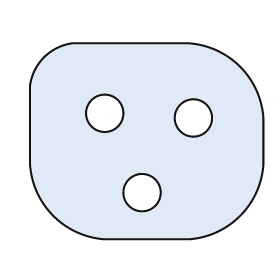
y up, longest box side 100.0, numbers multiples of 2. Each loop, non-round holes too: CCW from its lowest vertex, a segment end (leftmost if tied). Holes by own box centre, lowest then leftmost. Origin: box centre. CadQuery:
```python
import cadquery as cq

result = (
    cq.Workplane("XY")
    .moveTo(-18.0, -42.0)
    .lineTo(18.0, -42.0)
    .threePointArc((40.0, -32.0), (50.0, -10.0))
    .lineTo(50.0, 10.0)
    .threePointArc((40.0, 32.0), (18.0, 42.0))
    .lineTo(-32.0, 42.0)
    .threePointArc((-44.0, 36.0), (-50.0, 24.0))
    .lineTo(-50.0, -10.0)
    .threePointArc((-40.0, -32.0), (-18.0, -42.0))
    .close()
    .moveTo(-2.0, -22.0)
    .circle(8.0)
    .moveTo(20.0, 10.0)
    .circle(8.0)
    .moveTo(-18.0, 12.0)
    .circle(8.0)
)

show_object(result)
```